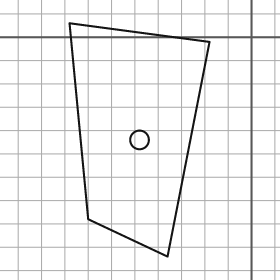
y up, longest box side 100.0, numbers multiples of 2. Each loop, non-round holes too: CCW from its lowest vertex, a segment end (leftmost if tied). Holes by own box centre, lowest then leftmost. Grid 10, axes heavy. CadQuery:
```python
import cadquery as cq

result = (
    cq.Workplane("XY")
    .moveTo(-36.0, -94.0)
    .lineTo(-18.0, -2.0)
    .lineTo(-78.0, 6.0)
    .lineTo(-70.0, -78.0)
    .close()
    .moveTo(-48.0, -44.0)
    .circle(4.0)
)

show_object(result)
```